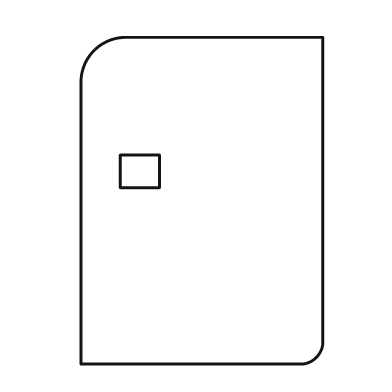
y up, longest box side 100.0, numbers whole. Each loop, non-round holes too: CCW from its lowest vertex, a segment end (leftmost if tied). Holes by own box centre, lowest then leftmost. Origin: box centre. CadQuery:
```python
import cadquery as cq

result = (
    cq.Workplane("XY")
    .moveTo(-37.0, -50.0)
    .lineTo(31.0, -50.0)
    .threePointArc((35.0, -48.0), (37.0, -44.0))
    .lineTo(37.0, 50.0)
    .lineTo(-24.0, 50.0)
    .threePointArc((-33.0, 46.0), (-37.0, 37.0))
    .close()
    .moveTo(-25.0, 4.0)
    .lineTo(-13.0, 4.0)
    .lineTo(-13.0, 14.0)
    .lineTo(-25.0, 14.0)
    .close()
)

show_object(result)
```